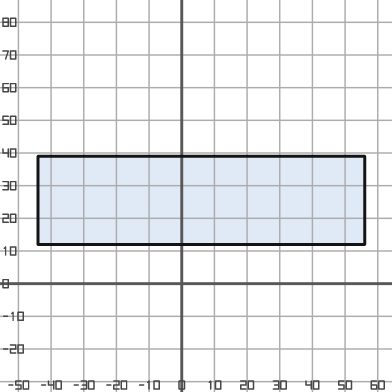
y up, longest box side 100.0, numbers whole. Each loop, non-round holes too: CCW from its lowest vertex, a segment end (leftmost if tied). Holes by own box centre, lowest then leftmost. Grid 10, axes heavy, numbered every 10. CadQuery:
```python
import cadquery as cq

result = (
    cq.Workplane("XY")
    .moveTo(-44.0, 12.0)
    .lineTo(56.0, 12.0)
    .lineTo(56.0, 39.0)
    .lineTo(-44.0, 39.0)
    .close()
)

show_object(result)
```